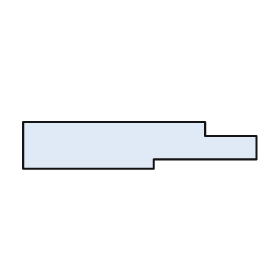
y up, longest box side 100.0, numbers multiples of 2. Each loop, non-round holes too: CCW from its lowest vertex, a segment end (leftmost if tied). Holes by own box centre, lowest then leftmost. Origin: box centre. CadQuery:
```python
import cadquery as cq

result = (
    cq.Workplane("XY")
    .moveTo(-50.0, -10.0)
    .lineTo(6.0, -10.0)
    .lineTo(6.0, -6.0)
    .lineTo(50.0, -6.0)
    .lineTo(50.0, 4.0)
    .lineTo(28.0, 4.0)
    .lineTo(28.0, 10.0)
    .lineTo(-50.0, 10.0)
    .close()
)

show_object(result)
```